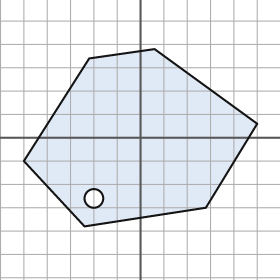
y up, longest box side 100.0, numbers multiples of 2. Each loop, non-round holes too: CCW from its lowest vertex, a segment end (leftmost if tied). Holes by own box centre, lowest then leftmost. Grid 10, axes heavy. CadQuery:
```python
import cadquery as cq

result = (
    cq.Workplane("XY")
    .moveTo(-24.0, -38.0)
    .lineTo(28.0, -30.0)
    .lineTo(50.0, 6.0)
    .lineTo(6.0, 38.0)
    .lineTo(-22.0, 34.0)
    .lineTo(-50.0, -10.0)
    .close()
    .moveTo(-20.0, -26.0)
    .circle(4.0)
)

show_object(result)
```